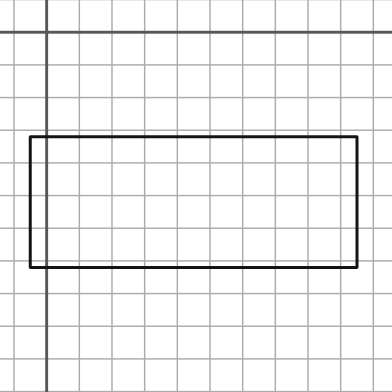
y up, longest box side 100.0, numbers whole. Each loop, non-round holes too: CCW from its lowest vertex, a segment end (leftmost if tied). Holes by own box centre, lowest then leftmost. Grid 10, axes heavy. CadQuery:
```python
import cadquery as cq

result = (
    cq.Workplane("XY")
    .moveTo(-5.0, -72.0)
    .lineTo(95.0, -72.0)
    .lineTo(95.0, -32.0)
    .lineTo(-5.0, -32.0)
    .close()
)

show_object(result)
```